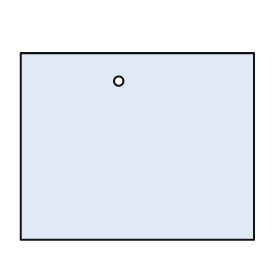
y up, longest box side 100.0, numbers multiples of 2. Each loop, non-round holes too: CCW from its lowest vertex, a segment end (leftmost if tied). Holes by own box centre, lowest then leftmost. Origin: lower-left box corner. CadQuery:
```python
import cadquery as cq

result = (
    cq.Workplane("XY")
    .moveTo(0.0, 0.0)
    .lineTo(100.0, 0.0)
    .lineTo(100.0, 80.0)
    .lineTo(0.0, 80.0)
    .close()
    .moveTo(42.0, 68.0)
    .circle(2.0)
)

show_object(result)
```